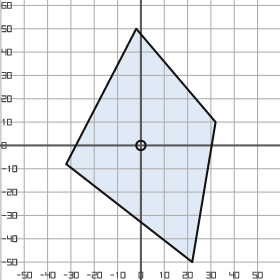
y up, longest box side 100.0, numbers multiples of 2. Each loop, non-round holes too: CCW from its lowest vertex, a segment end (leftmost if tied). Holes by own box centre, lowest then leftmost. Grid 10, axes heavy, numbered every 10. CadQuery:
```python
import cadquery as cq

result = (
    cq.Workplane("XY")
    .moveTo(22.0, -50.0)
    .lineTo(32.0, 10.0)
    .lineTo(-2.0, 50.0)
    .lineTo(-32.0, -8.0)
    .close()
    .moveTo(0.0, 0.0)
    .circle(2.0)
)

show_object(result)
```